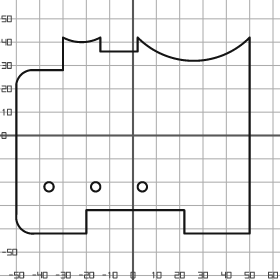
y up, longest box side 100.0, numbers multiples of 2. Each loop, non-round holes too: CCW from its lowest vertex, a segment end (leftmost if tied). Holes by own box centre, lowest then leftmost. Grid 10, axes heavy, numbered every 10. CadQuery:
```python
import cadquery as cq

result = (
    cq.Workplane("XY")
    .moveTo(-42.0, -42.0)
    .lineTo(-20.0, -42.0)
    .lineTo(-20.0, -32.0)
    .lineTo(22.0, -32.0)
    .lineTo(22.0, -42.0)
    .lineTo(50.0, -42.0)
    .lineTo(50.0, 42.0)
    .threePointArc((26.0, 32.0), (2.0, 42.0))
    .lineTo(2.0, 36.0)
    .lineTo(-14.0, 36.0)
    .lineTo(-14.0, 42.0)
    .threePointArc((-22.0, 40.0), (-30.0, 42.0))
    .lineTo(-30.0, 28.0)
    .lineTo(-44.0, 28.0)
    .threePointArc((-48.0, 26.0), (-50.0, 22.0))
    .lineTo(-50.0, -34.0)
    .threePointArc((-48.0, -40.0), (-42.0, -42.0))
    .close()
    .moveTo(-36.0, -22.0)
    .circle(2.0)
    .moveTo(-16.0, -22.0)
    .circle(2.0)
    .moveTo(4.0, -22.0)
    .circle(2.0)
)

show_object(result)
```